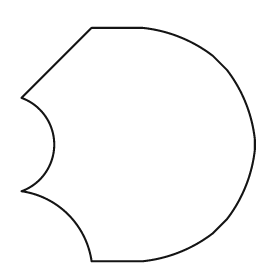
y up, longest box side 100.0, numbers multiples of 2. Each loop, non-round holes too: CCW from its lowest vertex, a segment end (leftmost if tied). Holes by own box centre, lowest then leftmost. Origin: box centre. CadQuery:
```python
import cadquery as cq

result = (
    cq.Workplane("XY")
    .moveTo(-20.0, -50.0)
    .lineTo(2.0, -50.0)
    .threePointArc((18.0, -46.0), (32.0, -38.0))
    .lineTo(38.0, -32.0)
    .threePointArc((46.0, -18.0), (50.0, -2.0))
    .lineTo(50.0, 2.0)
    .threePointArc((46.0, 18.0), (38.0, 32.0))
    .lineTo(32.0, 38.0)
    .threePointArc((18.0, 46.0), (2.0, 50.0))
    .lineTo(-20.0, 50.0)
    .lineTo(-50.0, 20.0)
    .threePointArc((-36.0, 0.0), (-50.0, -20.0))
    .threePointArc((-30.0, -30.0), (-20.0, -50.0))
    .close()
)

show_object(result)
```